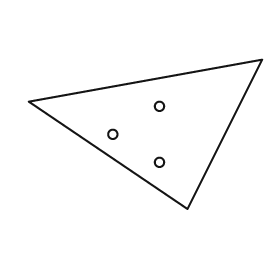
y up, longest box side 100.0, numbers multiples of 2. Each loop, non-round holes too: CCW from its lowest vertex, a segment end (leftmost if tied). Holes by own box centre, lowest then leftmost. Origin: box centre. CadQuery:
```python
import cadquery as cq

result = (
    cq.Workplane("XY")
    .moveTo(18.0, -32.0)
    .lineTo(50.0, 32.0)
    .lineTo(-50.0, 14.0)
    .close()
    .moveTo(6.0, -12.0)
    .circle(2.0)
    .moveTo(-14.0, 0.0)
    .circle(2.0)
    .moveTo(6.0, 12.0)
    .circle(2.0)
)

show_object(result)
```